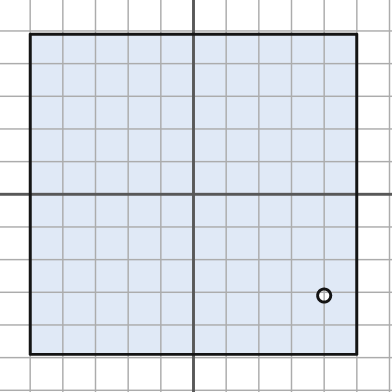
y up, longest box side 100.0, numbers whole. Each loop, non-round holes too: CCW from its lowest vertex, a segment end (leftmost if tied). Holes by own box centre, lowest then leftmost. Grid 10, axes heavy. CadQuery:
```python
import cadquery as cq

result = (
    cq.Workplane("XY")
    .moveTo(-50.0, -49.0)
    .lineTo(50.0, -49.0)
    .lineTo(50.0, 49.0)
    .lineTo(-50.0, 49.0)
    .close()
    .moveTo(40.0, -31.0)
    .circle(2.0)
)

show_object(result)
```